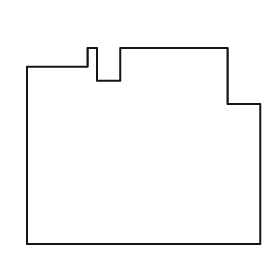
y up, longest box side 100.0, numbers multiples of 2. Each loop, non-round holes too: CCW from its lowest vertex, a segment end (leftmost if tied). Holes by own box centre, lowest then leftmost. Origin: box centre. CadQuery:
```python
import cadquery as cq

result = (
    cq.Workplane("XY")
    .moveTo(-50.0, -42.0)
    .lineTo(50.0, -42.0)
    .lineTo(50.0, 18.0)
    .lineTo(36.0, 18.0)
    .lineTo(36.0, 42.0)
    .lineTo(-10.0, 42.0)
    .lineTo(-10.0, 28.0)
    .lineTo(-20.0, 28.0)
    .lineTo(-20.0, 42.0)
    .lineTo(-24.0, 42.0)
    .lineTo(-24.0, 34.0)
    .lineTo(-50.0, 34.0)
    .close()
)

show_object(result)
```